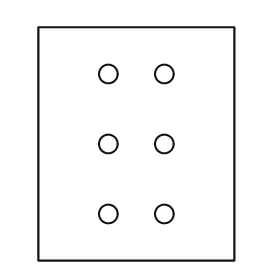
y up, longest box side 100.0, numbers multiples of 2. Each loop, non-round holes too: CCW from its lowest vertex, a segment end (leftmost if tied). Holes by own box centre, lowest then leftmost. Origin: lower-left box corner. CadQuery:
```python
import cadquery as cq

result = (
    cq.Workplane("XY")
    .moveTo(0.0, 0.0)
    .lineTo(84.0, 0.0)
    .lineTo(84.0, 100.0)
    .lineTo(0.0, 100.0)
    .close()
    .moveTo(30.0, 20.0)
    .circle(4.0)
    .moveTo(54.0, 20.0)
    .circle(4.0)
    .moveTo(30.0, 50.0)
    .circle(4.0)
    .moveTo(54.0, 50.0)
    .circle(4.0)
    .moveTo(30.0, 80.0)
    .circle(4.0)
    .moveTo(54.0, 80.0)
    .circle(4.0)
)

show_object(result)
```